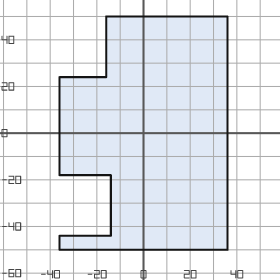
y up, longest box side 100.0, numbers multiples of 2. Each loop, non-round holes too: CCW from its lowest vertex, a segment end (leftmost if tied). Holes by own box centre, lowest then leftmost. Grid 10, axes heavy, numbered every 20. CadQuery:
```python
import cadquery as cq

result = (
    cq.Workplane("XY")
    .moveTo(-36.0, -50.0)
    .lineTo(36.0, -50.0)
    .lineTo(36.0, 50.0)
    .lineTo(-16.0, 50.0)
    .lineTo(-16.0, 24.0)
    .lineTo(-36.0, 24.0)
    .lineTo(-36.0, -18.0)
    .lineTo(-14.0, -18.0)
    .lineTo(-14.0, -44.0)
    .lineTo(-36.0, -44.0)
    .close()
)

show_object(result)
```